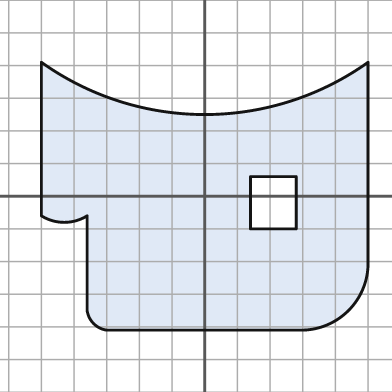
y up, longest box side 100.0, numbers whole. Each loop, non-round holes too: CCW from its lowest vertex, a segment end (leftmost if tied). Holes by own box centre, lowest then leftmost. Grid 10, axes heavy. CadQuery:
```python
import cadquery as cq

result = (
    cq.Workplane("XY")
    .moveTo(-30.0, -41.0)
    .lineTo(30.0, -41.0)
    .threePointArc((44.0, -35.0), (50.0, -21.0))
    .lineTo(50.0, 41.0)
    .threePointArc((0.0, 25.0), (-50.0, 41.0))
    .lineTo(-50.0, -6.0)
    .threePointArc((-43.0, -8.0), (-36.0, -6.0))
    .lineTo(-36.0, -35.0)
    .threePointArc((-34.0, -39.0), (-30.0, -41.0))
    .close()
    .moveTo(14.0, -10.0)
    .lineTo(28.0, -10.0)
    .lineTo(28.0, 6.0)
    .lineTo(14.0, 6.0)
    .close()
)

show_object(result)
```